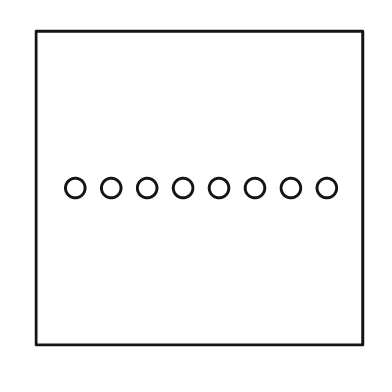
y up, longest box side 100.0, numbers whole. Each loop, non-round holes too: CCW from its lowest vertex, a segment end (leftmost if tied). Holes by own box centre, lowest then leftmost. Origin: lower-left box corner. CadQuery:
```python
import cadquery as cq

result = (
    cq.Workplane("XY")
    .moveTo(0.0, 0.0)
    .lineTo(100.0, 0.0)
    .lineTo(100.0, 96.0)
    .lineTo(0.0, 96.0)
    .close()
    .moveTo(12.0, 48.0)
    .circle(3.0)
    .moveTo(23.0, 48.0)
    .circle(3.0)
    .moveTo(34.0, 48.0)
    .circle(3.0)
    .moveTo(45.0, 48.0)
    .circle(3.0)
    .moveTo(56.0, 48.0)
    .circle(3.0)
    .moveTo(67.0, 48.0)
    .circle(3.0)
    .moveTo(78.0, 48.0)
    .circle(3.0)
    .moveTo(89.0, 48.0)
    .circle(3.0)
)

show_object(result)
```